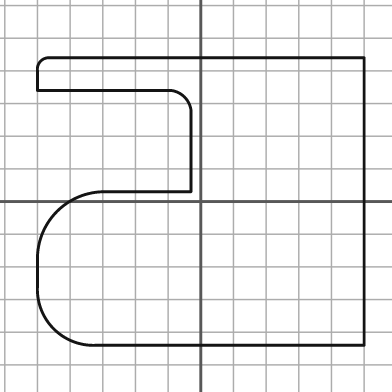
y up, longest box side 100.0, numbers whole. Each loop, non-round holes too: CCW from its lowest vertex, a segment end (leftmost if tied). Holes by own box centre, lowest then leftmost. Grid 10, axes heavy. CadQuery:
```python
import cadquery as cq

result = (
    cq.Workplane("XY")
    .moveTo(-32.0, -44.0)
    .lineTo(50.0, -44.0)
    .lineTo(50.0, 44.0)
    .lineTo(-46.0, 44.0)
    .threePointArc((-49.0, 43.0), (-50.0, 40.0))
    .lineTo(-50.0, 34.0)
    .lineTo(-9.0, 34.0)
    .threePointArc((-5.0, 32.0), (-3.0, 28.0))
    .lineTo(-3.0, 3.0)
    .lineTo(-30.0, 3.0)
    .threePointArc((-44.0, -3.0), (-50.0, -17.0))
    .lineTo(-50.0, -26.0)
    .threePointArc((-45.0, -39.0), (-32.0, -44.0))
    .close()
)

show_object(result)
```